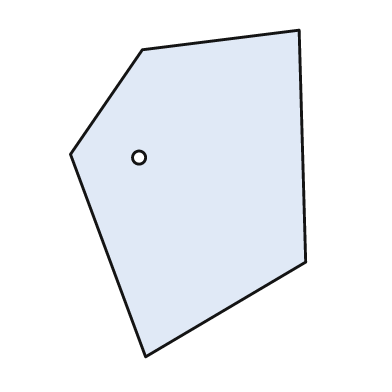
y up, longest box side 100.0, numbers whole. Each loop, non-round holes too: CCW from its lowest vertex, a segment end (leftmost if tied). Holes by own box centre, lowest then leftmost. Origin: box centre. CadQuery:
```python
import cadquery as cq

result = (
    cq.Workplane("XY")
    .moveTo(-13.0, -50.0)
    .lineTo(36.0, -21.0)
    .lineTo(34.0, 50.0)
    .lineTo(-14.0, 44.0)
    .lineTo(-36.0, 12.0)
    .close()
    .moveTo(-15.0, 11.0)
    .circle(2.0)
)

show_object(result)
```